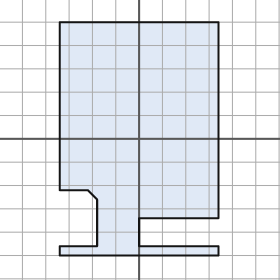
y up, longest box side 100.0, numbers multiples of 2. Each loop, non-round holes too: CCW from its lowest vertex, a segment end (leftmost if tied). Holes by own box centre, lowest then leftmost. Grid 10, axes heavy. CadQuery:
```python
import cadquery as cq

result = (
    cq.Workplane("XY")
    .moveTo(-34.0, -50.0)
    .lineTo(34.0, -50.0)
    .lineTo(34.0, -46.0)
    .lineTo(0.0, -46.0)
    .lineTo(0.0, -34.0)
    .lineTo(34.0, -34.0)
    .lineTo(34.0, 50.0)
    .lineTo(-34.0, 50.0)
    .lineTo(-34.0, -22.0)
    .lineTo(-22.0, -22.0)
    .lineTo(-18.0, -26.0)
    .lineTo(-18.0, -46.0)
    .lineTo(-34.0, -46.0)
    .close()
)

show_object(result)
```